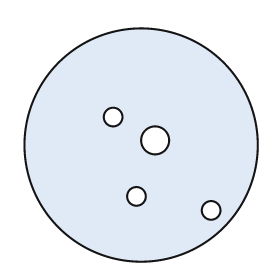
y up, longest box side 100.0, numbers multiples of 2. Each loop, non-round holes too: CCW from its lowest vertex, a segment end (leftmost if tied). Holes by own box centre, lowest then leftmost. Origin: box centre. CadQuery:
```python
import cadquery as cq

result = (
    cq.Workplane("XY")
    .moveTo(0.0, 0.0)
    .circle(50.0)
    .moveTo(30.0, -28.0)
    .circle(4.0)
    .moveTo(-2.0, -22.0)
    .circle(4.0)
    .moveTo(6.0, 2.0)
    .circle(6.0)
    .moveTo(-12.0, 12.0)
    .circle(4.0)
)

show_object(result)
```